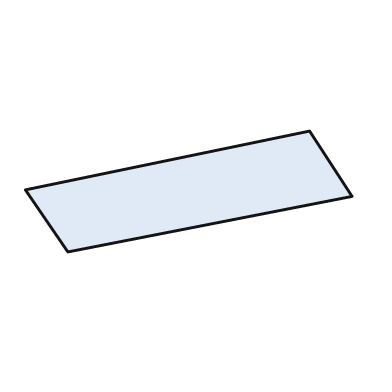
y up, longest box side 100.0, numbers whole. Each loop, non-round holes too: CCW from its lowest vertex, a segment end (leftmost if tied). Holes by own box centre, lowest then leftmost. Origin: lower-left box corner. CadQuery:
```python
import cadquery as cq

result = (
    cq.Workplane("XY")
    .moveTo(13.0, 0.0)
    .lineTo(100.0, 17.0)
    .lineTo(87.0, 37.0)
    .lineTo(0.0, 19.0)
    .close()
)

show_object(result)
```